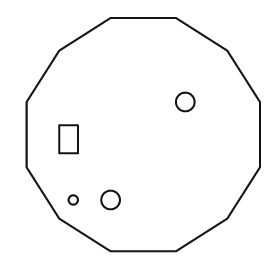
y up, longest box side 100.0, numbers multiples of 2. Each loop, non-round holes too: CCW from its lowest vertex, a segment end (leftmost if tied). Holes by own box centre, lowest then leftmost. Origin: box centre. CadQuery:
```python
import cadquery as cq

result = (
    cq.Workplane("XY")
    .moveTo(-14.0, -50.0)
    .lineTo(14.0, -50.0)
    .lineTo(36.0, -36.0)
    .lineTo(50.0, -14.0)
    .lineTo(50.0, 14.0)
    .lineTo(36.0, 36.0)
    .lineTo(14.0, 50.0)
    .lineTo(-14.0, 50.0)
    .lineTo(-36.0, 36.0)
    .lineTo(-50.0, 14.0)
    .lineTo(-50.0, -14.0)
    .lineTo(-36.0, -36.0)
    .close()
    .moveTo(-30.0, -28.0)
    .circle(2.0)
    .moveTo(-14.0, -28.0)
    .circle(4.0)
    .moveTo(-36.0, -8.0)
    .lineTo(-28.0, -8.0)
    .lineTo(-28.0, 4.0)
    .lineTo(-36.0, 4.0)
    .close()
    .moveTo(18.0, 14.0)
    .circle(4.0)
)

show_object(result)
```